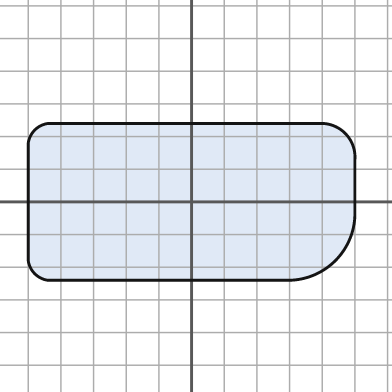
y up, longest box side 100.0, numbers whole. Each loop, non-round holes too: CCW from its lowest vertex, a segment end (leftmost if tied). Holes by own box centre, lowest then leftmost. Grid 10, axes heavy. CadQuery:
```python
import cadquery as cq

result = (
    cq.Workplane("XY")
    .moveTo(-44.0, -24.0)
    .lineTo(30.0, -24.0)
    .threePointArc((44.0, -18.0), (50.0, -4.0))
    .lineTo(50.0, 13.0)
    .threePointArc((47.0, 21.0), (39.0, 24.0))
    .lineTo(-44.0, 24.0)
    .threePointArc((-48.0, 22.0), (-50.0, 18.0))
    .lineTo(-50.0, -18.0)
    .threePointArc((-48.0, -22.0), (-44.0, -24.0))
    .close()
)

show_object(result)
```